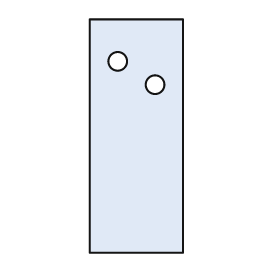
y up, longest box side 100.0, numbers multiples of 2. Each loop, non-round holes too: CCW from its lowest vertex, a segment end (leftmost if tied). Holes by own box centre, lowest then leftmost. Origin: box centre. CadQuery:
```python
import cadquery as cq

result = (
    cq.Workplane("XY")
    .moveTo(-20.0, -50.0)
    .lineTo(20.0, -50.0)
    .lineTo(20.0, 50.0)
    .lineTo(-20.0, 50.0)
    .close()
    .moveTo(8.0, 22.0)
    .circle(4.0)
    .moveTo(-8.0, 32.0)
    .circle(4.0)
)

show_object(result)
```